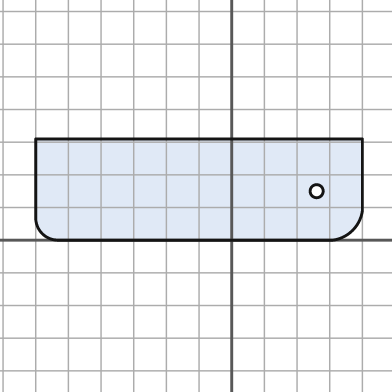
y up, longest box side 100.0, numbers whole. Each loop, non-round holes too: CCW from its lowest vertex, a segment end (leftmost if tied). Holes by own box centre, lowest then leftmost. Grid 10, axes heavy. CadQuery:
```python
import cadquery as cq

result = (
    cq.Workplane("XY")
    .moveTo(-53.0, 0.0)
    .lineTo(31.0, 0.0)
    .threePointArc((37.0, 3.0), (40.0, 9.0))
    .lineTo(40.0, 31.0)
    .lineTo(-60.0, 31.0)
    .lineTo(-60.0, 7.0)
    .threePointArc((-58.0, 2.0), (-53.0, 0.0))
    .close()
    .moveTo(26.0, 15.0)
    .circle(2.0)
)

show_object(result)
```